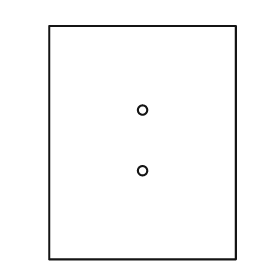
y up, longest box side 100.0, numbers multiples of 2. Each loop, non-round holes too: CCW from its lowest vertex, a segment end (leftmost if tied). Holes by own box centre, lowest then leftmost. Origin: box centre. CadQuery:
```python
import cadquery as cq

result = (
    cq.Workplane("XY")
    .moveTo(-40.0, -50.0)
    .lineTo(40.0, -50.0)
    .lineTo(40.0, 50.0)
    .lineTo(-40.0, 50.0)
    .close()
    .moveTo(0.0, -12.0)
    .circle(2.0)
    .moveTo(0.0, 14.0)
    .circle(2.0)
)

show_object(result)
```